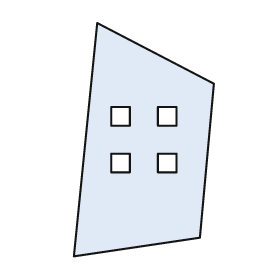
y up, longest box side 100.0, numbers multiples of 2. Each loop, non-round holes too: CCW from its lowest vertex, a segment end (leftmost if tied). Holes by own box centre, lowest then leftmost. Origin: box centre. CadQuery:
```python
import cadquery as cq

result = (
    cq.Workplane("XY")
    .moveTo(-30.0, -50.0)
    .lineTo(24.0, -42.0)
    .lineTo(30.0, 24.0)
    .lineTo(-20.0, 50.0)
    .close()
    .moveTo(-14.0, -14.0)
    .lineTo(-6.0, -14.0)
    .lineTo(-6.0, -6.0)
    .lineTo(-14.0, -6.0)
    .close()
    .moveTo(6.0, -14.0)
    .lineTo(14.0, -14.0)
    .lineTo(14.0, -6.0)
    .lineTo(6.0, -6.0)
    .close()
    .moveTo(-14.0, 6.0)
    .lineTo(-6.0, 6.0)
    .lineTo(-6.0, 14.0)
    .lineTo(-14.0, 14.0)
    .close()
    .moveTo(6.0, 6.0)
    .lineTo(14.0, 6.0)
    .lineTo(14.0, 14.0)
    .lineTo(6.0, 14.0)
    .close()
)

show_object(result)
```